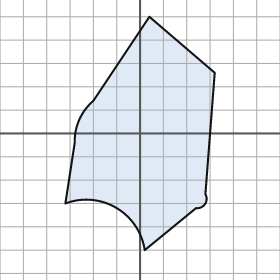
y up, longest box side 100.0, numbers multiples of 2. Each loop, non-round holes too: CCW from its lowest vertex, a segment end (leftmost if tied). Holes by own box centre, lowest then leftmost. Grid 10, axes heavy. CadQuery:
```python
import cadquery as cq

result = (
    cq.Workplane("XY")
    .moveTo(2.0, -50.0)
    .lineTo(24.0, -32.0)
    .threePointArc((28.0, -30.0), (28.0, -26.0))
    .lineTo(32.0, 26.0)
    .lineTo(4.0, 50.0)
    .lineTo(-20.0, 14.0)
    .threePointArc((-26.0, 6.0), (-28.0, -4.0))
    .lineTo(-32.0, -30.0)
    .threePointArc((-10.0, -32.0), (2.0, -50.0))
    .close()
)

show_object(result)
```